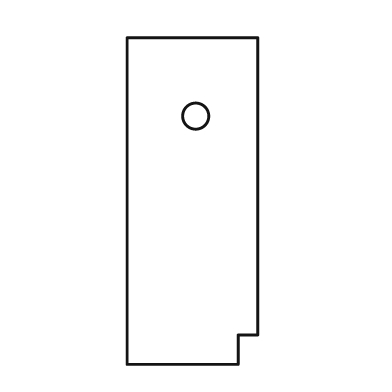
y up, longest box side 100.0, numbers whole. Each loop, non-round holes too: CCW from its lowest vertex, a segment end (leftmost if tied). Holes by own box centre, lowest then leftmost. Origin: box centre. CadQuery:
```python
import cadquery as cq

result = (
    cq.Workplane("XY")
    .moveTo(-20.0, -50.0)
    .lineTo(14.0, -50.0)
    .lineTo(14.0, -41.0)
    .lineTo(20.0, -41.0)
    .lineTo(20.0, 50.0)
    .lineTo(-20.0, 50.0)
    .close()
    .moveTo(1.0, 26.0)
    .circle(4.0)
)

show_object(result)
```